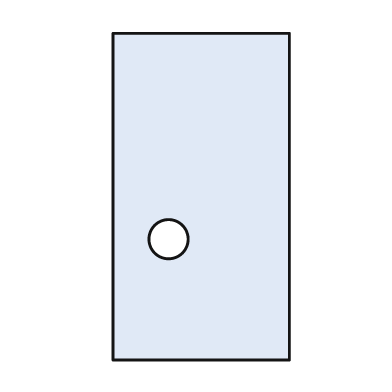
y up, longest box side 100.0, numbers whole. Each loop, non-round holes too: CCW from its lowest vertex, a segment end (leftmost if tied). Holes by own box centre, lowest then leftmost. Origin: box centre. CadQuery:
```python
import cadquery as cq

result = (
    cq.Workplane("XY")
    .moveTo(-27.0, -50.0)
    .lineTo(27.0, -50.0)
    .lineTo(27.0, 50.0)
    .lineTo(-27.0, 50.0)
    .close()
    .moveTo(-10.0, -13.0)
    .circle(6.0)
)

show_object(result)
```